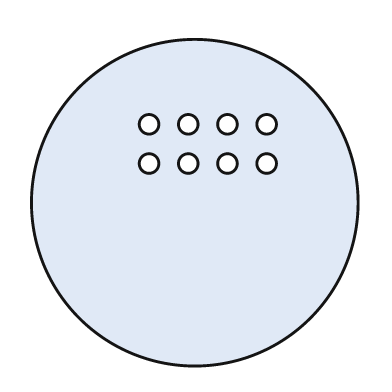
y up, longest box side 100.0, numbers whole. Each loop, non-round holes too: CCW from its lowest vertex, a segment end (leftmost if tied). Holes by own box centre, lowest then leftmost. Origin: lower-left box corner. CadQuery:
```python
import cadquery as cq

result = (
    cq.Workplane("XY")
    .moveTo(50.0, 50.0)
    .circle(50.0)
    .moveTo(36.0, 62.0)
    .circle(3.0)
    .moveTo(48.0, 62.0)
    .circle(3.0)
    .moveTo(60.0, 62.0)
    .circle(3.0)
    .moveTo(72.0, 62.0)
    .circle(3.0)
    .moveTo(36.0, 74.0)
    .circle(3.0)
    .moveTo(48.0, 74.0)
    .circle(3.0)
    .moveTo(60.0, 74.0)
    .circle(3.0)
    .moveTo(72.0, 74.0)
    .circle(3.0)
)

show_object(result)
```